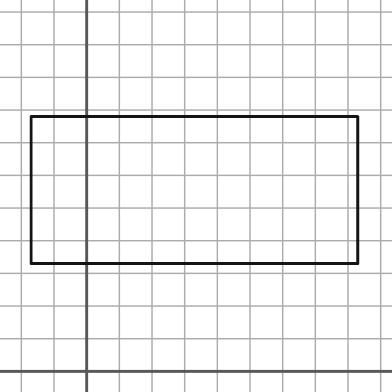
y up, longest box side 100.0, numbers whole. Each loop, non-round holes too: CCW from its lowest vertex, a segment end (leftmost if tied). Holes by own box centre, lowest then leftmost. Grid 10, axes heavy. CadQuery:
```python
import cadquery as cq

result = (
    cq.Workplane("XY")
    .moveTo(-17.0, 33.0)
    .lineTo(83.0, 33.0)
    .lineTo(83.0, 78.0)
    .lineTo(-17.0, 78.0)
    .close()
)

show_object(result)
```